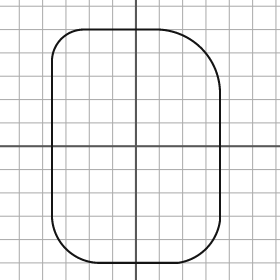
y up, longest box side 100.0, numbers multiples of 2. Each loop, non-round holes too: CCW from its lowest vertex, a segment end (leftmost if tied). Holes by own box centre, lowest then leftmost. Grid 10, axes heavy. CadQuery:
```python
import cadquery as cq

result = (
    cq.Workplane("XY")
    .moveTo(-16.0, -50.0)
    .lineTo(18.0, -50.0)
    .threePointArc((30.0, -44.0), (36.0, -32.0))
    .lineTo(36.0, 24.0)
    .threePointArc((28.0, 42.0), (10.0, 50.0))
    .lineTo(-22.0, 50.0)
    .threePointArc((-32.0, 46.0), (-36.0, 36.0))
    .lineTo(-36.0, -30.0)
    .threePointArc((-30.0, -44.0), (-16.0, -50.0))
    .close()
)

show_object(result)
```